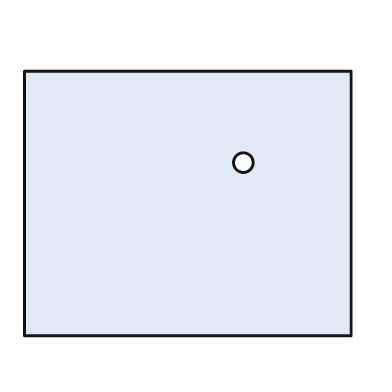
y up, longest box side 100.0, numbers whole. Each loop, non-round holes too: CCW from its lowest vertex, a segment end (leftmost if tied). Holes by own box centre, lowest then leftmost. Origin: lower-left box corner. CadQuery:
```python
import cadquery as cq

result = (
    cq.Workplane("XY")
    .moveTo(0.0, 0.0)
    .lineTo(100.0, 0.0)
    .lineTo(100.0, 81.0)
    .lineTo(0.0, 81.0)
    .close()
    .moveTo(67.0, 53.0)
    .circle(3.0)
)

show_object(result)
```